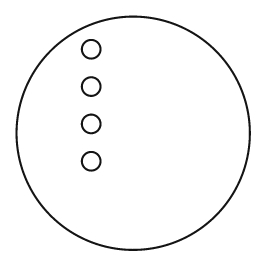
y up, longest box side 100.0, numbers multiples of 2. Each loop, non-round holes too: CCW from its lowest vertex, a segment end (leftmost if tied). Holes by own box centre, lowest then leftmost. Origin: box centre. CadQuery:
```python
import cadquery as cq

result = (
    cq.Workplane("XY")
    .moveTo(0.0, 0.0)
    .circle(50.0)
    .moveTo(-18.0, -12.0)
    .circle(4.0)
    .moveTo(-18.0, 4.0)
    .circle(4.0)
    .moveTo(-18.0, 20.0)
    .circle(4.0)
    .moveTo(-18.0, 36.0)
    .circle(4.0)
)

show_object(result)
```